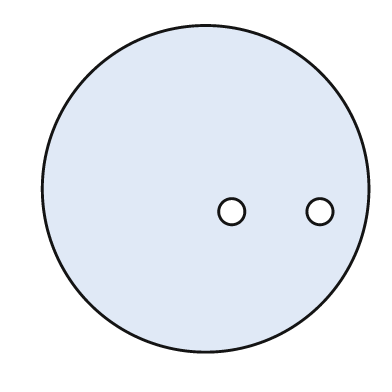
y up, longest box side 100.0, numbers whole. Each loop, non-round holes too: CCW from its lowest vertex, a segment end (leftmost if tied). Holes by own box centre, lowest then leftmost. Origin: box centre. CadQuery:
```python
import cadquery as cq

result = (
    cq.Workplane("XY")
    .moveTo(0.0, 0.0)
    .circle(50.0)
    .moveTo(8.0, -7.0)
    .circle(4.0)
    .moveTo(35.0, -7.0)
    .circle(4.0)
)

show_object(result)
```